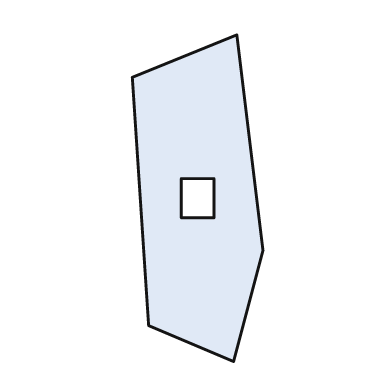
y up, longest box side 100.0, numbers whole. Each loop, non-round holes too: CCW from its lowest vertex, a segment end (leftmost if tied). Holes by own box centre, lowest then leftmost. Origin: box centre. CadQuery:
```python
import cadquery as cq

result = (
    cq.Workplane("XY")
    .moveTo(11.0, -50.0)
    .lineTo(20.0, -16.0)
    .lineTo(12.0, 50.0)
    .lineTo(-20.0, 37.0)
    .lineTo(-15.0, -39.0)
    .close()
    .moveTo(-5.0, -6.0)
    .lineTo(5.0, -6.0)
    .lineTo(5.0, 6.0)
    .lineTo(-5.0, 6.0)
    .close()
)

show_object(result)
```